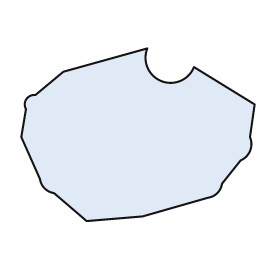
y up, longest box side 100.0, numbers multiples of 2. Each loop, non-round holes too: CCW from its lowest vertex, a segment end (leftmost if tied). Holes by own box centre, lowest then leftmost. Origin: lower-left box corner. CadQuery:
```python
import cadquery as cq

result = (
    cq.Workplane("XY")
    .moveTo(28.0, 0.0)
    .lineTo(52.0, 2.0)
    .lineTo(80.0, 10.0)
    .threePointArc((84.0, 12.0), (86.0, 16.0))
    .lineTo(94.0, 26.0)
    .threePointArc((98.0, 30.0), (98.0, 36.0))
    .lineTo(100.0, 50.0)
    .lineTo(74.0, 66.0)
    .threePointArc((60.0, 60.0), (54.0, 74.0))
    .lineTo(18.0, 64.0)
    .lineTo(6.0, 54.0)
    .threePointArc((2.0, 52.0), (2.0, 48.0))
    .lineTo(0.0, 36.0)
    .lineTo(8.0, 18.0)
    .threePointArc((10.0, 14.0), (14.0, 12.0))
    .close()
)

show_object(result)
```